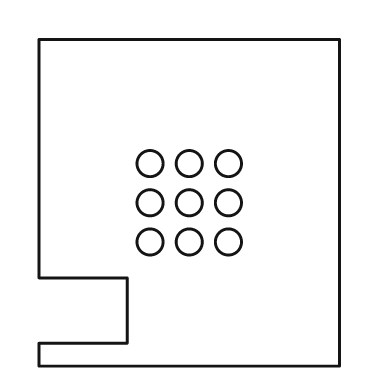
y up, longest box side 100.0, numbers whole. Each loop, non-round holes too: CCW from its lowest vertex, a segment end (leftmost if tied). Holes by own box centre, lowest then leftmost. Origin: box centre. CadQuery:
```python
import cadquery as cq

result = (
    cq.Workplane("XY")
    .moveTo(-46.0, -50.0)
    .lineTo(46.0, -50.0)
    .lineTo(46.0, 50.0)
    .lineTo(-46.0, 50.0)
    .lineTo(-46.0, -23.0)
    .lineTo(-19.0, -23.0)
    .lineTo(-19.0, -43.0)
    .lineTo(-46.0, -43.0)
    .close()
    .moveTo(-12.0, -12.0)
    .circle(4.0)
    .moveTo(0.0, -12.0)
    .circle(4.0)
    .moveTo(12.0, -12.0)
    .circle(4.0)
    .moveTo(-12.0, 0.0)
    .circle(4.0)
    .moveTo(0.0, 0.0)
    .circle(4.0)
    .moveTo(12.0, 0.0)
    .circle(4.0)
    .moveTo(-12.0, 12.0)
    .circle(4.0)
    .moveTo(0.0, 12.0)
    .circle(4.0)
    .moveTo(12.0, 12.0)
    .circle(4.0)
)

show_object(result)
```